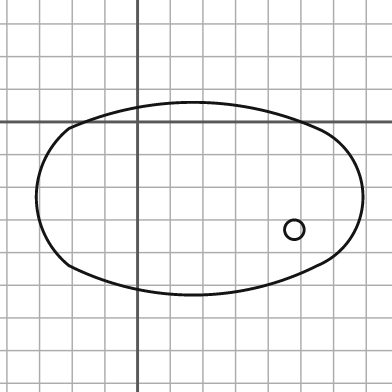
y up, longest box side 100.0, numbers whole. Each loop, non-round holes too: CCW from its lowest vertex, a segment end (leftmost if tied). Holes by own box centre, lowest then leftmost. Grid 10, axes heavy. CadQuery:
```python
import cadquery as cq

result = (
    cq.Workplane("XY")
    .moveTo(-21.0, -44.0)
    .threePointArc((17.0, -53.0), (55.0, -44.0))
    .threePointArc((69.0, -23.0), (55.0, -2.0))
    .threePointArc((17.0, 6.0), (-21.0, -2.0))
    .threePointArc((-31.0, -23.0), (-21.0, -44.0))
    .close()
    .moveTo(48.0, -33.0)
    .circle(3.0)
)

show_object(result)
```